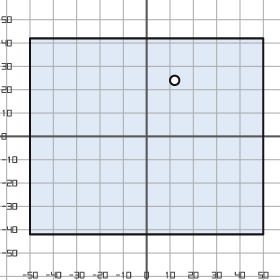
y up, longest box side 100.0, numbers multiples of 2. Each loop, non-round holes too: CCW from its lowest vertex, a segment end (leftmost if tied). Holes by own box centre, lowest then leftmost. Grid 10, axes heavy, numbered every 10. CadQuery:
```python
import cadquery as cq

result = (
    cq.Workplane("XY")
    .moveTo(-50.0, -42.0)
    .lineTo(50.0, -42.0)
    .lineTo(50.0, 42.0)
    .lineTo(-50.0, 42.0)
    .close()
    .moveTo(12.0, 24.0)
    .circle(2.0)
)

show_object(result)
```